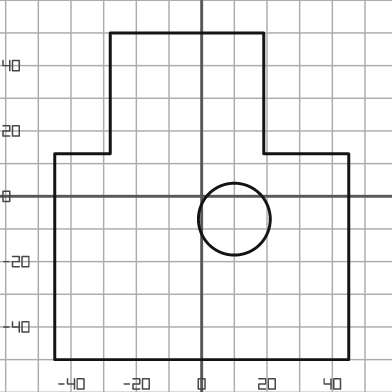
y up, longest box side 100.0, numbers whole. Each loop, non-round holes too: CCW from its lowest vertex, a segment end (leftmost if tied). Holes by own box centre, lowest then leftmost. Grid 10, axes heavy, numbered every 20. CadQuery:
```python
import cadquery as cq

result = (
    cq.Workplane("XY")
    .moveTo(-45.0, -50.0)
    .lineTo(45.0, -50.0)
    .lineTo(45.0, 13.0)
    .lineTo(19.0, 13.0)
    .lineTo(19.0, 50.0)
    .lineTo(-28.0, 50.0)
    .lineTo(-28.0, 13.0)
    .lineTo(-45.0, 13.0)
    .close()
    .moveTo(10.0, -7.0)
    .circle(11.0)
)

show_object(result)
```